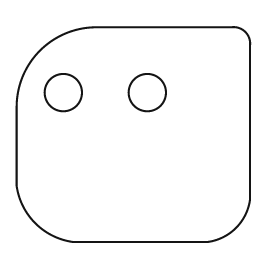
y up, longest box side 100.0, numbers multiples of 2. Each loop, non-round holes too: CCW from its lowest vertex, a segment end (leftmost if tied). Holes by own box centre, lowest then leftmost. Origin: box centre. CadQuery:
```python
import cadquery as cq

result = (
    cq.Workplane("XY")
    .moveTo(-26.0, -46.0)
    .lineTo(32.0, -46.0)
    .threePointArc((44.0, -40.0), (50.0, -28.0))
    .lineTo(50.0, 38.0)
    .threePointArc((48.0, 44.0), (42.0, 46.0))
    .lineTo(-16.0, 46.0)
    .threePointArc((-40.0, 36.0), (-50.0, 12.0))
    .lineTo(-50.0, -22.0)
    .threePointArc((-42.0, -38.0), (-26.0, -46.0))
    .close()
    .moveTo(-30.0, 18.0)
    .circle(8.0)
    .moveTo(6.0, 18.0)
    .circle(8.0)
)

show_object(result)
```